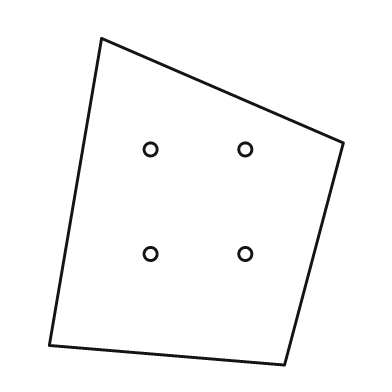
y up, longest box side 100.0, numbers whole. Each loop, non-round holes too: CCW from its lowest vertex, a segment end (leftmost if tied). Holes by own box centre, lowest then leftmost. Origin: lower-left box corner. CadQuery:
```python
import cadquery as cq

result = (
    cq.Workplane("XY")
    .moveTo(72.0, 0.0)
    .lineTo(90.0, 68.0)
    .lineTo(16.0, 100.0)
    .lineTo(0.0, 6.0)
    .close()
    .moveTo(31.0, 34.0)
    .circle(2.0)
    .moveTo(60.0, 34.0)
    .circle(2.0)
    .moveTo(31.0, 66.0)
    .circle(2.0)
    .moveTo(60.0, 66.0)
    .circle(2.0)
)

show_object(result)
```